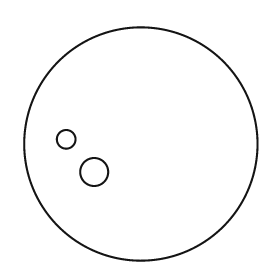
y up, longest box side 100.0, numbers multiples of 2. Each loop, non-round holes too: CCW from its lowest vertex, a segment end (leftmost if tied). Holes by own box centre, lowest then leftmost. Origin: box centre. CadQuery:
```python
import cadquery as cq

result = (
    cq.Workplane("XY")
    .moveTo(0.0, 0.0)
    .circle(50.0)
    .moveTo(-20.0, -12.0)
    .circle(6.0)
    .moveTo(-32.0, 2.0)
    .circle(4.0)
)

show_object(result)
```